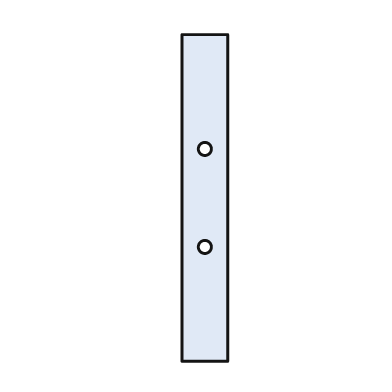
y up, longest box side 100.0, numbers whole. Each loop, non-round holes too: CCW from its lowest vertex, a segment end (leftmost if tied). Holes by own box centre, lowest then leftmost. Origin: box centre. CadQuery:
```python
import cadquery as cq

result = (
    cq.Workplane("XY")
    .moveTo(-7.0, -50.0)
    .lineTo(7.0, -50.0)
    .lineTo(7.0, 50.0)
    .lineTo(-7.0, 50.0)
    .close()
    .moveTo(0.0, -15.0)
    .circle(2.0)
    .moveTo(0.0, 15.0)
    .circle(2.0)
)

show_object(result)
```